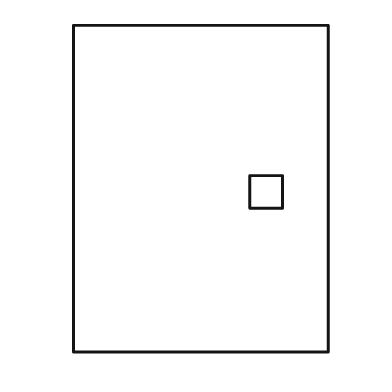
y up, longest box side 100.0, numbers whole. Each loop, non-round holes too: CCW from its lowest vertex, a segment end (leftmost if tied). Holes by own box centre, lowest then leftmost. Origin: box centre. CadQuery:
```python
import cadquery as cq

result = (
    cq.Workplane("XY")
    .moveTo(-39.0, -50.0)
    .lineTo(39.0, -50.0)
    .lineTo(39.0, 50.0)
    .lineTo(-39.0, 50.0)
    .close()
    .moveTo(15.0, -6.0)
    .lineTo(25.0, -6.0)
    .lineTo(25.0, 4.0)
    .lineTo(15.0, 4.0)
    .close()
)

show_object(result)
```